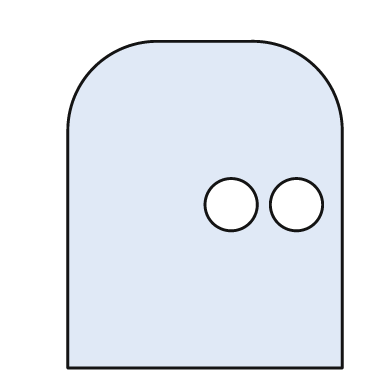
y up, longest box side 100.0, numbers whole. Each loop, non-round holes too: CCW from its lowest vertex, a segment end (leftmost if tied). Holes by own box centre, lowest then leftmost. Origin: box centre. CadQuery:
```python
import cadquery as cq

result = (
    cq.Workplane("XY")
    .moveTo(-42.0, -50.0)
    .lineTo(42.0, -50.0)
    .lineTo(42.0, 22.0)
    .threePointArc((34.0, 42.0), (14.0, 50.0))
    .lineTo(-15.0, 50.0)
    .threePointArc((-34.0, 42.0), (-42.0, 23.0))
    .close()
    .moveTo(8.0, 0.0)
    .circle(8.0)
    .moveTo(28.0, 0.0)
    .circle(8.0)
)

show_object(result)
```